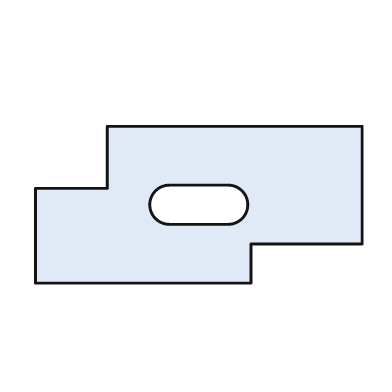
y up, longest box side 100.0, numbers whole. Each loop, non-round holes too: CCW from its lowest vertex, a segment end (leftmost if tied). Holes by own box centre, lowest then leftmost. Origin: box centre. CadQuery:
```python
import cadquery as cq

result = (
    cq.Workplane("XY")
    .moveTo(-50.0, -24.0)
    .lineTo(16.0, -24.0)
    .lineTo(16.0, -12.0)
    .lineTo(50.0, -12.0)
    .lineTo(50.0, 24.0)
    .lineTo(-28.0, 24.0)
    .lineTo(-28.0, 5.0)
    .lineTo(-50.0, 5.0)
    .close()
    .moveTo(-9.0, -6.0)
    .lineTo(9.0, -6.0)
    .threePointArc((15.0, 0.0), (9.0, 6.0))
    .lineTo(-9.0, 6.0)
    .threePointArc((-15.0, 0.0), (-9.0, -6.0))
    .close()
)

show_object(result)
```